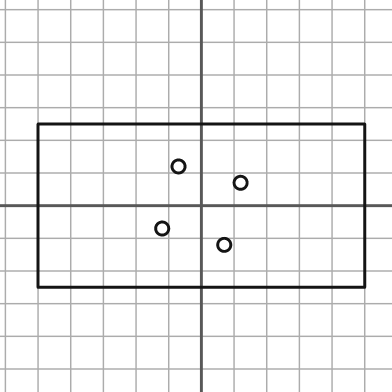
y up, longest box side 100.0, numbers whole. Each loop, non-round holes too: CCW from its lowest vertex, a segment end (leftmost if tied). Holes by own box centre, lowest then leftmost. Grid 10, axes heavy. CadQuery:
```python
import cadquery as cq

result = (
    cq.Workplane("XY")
    .moveTo(-50.0, -25.0)
    .lineTo(50.0, -25.0)
    .lineTo(50.0, 25.0)
    .lineTo(-50.0, 25.0)
    .close()
    .moveTo(7.0, -12.0)
    .circle(2.0)
    .moveTo(-12.0, -7.0)
    .circle(2.0)
    .moveTo(12.0, 7.0)
    .circle(2.0)
    .moveTo(-7.0, 12.0)
    .circle(2.0)
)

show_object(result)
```